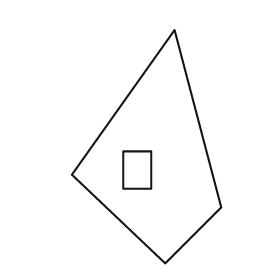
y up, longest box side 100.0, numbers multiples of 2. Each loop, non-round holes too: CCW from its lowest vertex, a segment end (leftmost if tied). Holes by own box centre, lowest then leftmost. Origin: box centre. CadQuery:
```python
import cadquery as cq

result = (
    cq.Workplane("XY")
    .moveTo(8.0, -50.0)
    .lineTo(32.0, -26.0)
    .lineTo(12.0, 50.0)
    .lineTo(-32.0, -12.0)
    .close()
    .moveTo(-10.0, -18.0)
    .lineTo(2.0, -18.0)
    .lineTo(2.0, -2.0)
    .lineTo(-10.0, -2.0)
    .close()
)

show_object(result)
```